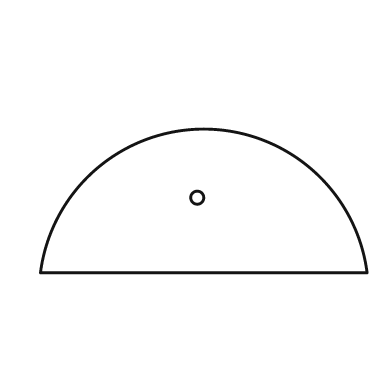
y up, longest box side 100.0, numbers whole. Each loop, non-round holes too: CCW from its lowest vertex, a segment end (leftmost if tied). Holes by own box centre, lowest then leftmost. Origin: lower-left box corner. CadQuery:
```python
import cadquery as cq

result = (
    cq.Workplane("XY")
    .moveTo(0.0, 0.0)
    .lineTo(100.0, 0.0)
    .threePointArc((50.0, 44.0), (0.0, 0.0))
    .close()
    .moveTo(48.0, 23.0)
    .circle(2.0)
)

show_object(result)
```